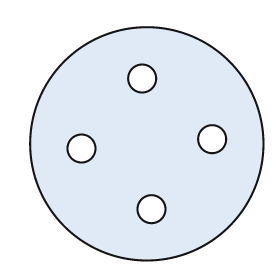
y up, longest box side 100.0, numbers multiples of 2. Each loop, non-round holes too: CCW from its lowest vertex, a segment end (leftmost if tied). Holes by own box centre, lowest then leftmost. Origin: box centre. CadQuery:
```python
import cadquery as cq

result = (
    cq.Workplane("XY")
    .moveTo(0.0, 0.0)
    .circle(50.0)
    .moveTo(2.0, -28.0)
    .circle(6.0)
    .moveTo(-28.0, -2.0)
    .circle(6.0)
    .moveTo(28.0, 2.0)
    .circle(6.0)
    .moveTo(-2.0, 28.0)
    .circle(6.0)
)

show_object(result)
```